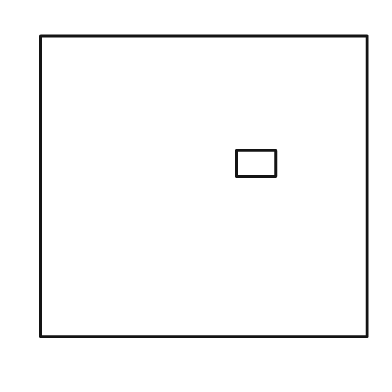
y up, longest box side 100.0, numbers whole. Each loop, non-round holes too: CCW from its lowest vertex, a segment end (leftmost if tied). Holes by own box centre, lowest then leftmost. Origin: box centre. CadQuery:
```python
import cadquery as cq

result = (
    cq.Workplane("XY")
    .moveTo(-50.0, -46.0)
    .lineTo(50.0, -46.0)
    .lineTo(50.0, 46.0)
    .lineTo(-50.0, 46.0)
    .close()
    .moveTo(10.0, 3.0)
    .lineTo(22.0, 3.0)
    .lineTo(22.0, 11.0)
    .lineTo(10.0, 11.0)
    .close()
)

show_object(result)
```